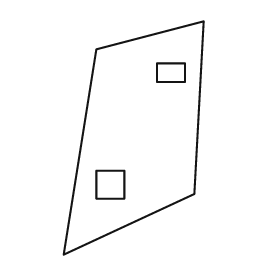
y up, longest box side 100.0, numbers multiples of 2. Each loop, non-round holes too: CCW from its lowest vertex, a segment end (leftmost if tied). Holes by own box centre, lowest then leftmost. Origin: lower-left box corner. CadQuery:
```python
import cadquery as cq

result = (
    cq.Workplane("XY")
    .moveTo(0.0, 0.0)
    .lineTo(56.0, 26.0)
    .lineTo(60.0, 100.0)
    .lineTo(14.0, 88.0)
    .close()
    .moveTo(14.0, 24.0)
    .lineTo(26.0, 24.0)
    .lineTo(26.0, 36.0)
    .lineTo(14.0, 36.0)
    .close()
    .moveTo(40.0, 74.0)
    .lineTo(52.0, 74.0)
    .lineTo(52.0, 82.0)
    .lineTo(40.0, 82.0)
    .close()
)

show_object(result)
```